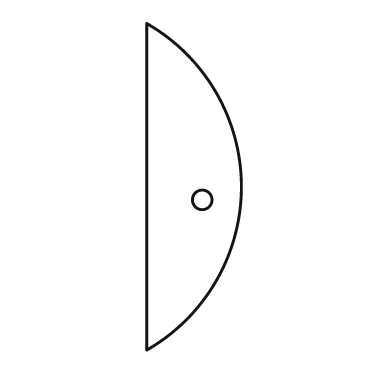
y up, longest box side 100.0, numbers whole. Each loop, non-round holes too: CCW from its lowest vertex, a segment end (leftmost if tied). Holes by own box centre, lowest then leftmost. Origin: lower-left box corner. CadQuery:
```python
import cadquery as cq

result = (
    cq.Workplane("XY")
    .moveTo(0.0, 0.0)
    .threePointArc((29.0, 50.0), (0.0, 100.0))
    .close()
    .moveTo(17.0, 46.0)
    .circle(3.0)
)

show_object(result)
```